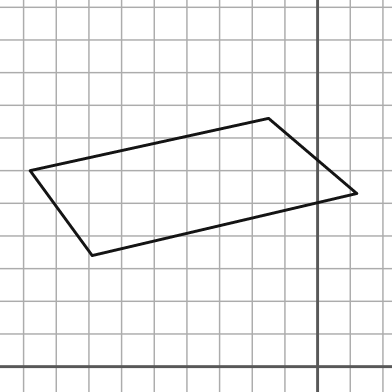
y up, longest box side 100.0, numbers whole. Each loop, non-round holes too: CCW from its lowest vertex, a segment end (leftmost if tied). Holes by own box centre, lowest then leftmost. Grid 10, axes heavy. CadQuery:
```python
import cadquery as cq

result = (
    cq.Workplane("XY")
    .moveTo(-69.0, 34.0)
    .lineTo(12.0, 53.0)
    .lineTo(-15.0, 76.0)
    .lineTo(-88.0, 60.0)
    .close()
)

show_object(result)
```